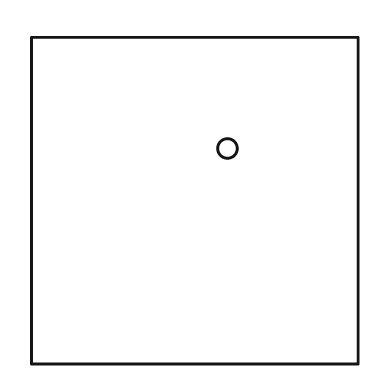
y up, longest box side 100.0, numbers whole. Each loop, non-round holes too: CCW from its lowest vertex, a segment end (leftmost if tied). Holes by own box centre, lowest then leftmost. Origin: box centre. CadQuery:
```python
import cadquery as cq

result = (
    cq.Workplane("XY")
    .moveTo(-50.0, -50.0)
    .lineTo(50.0, -50.0)
    .lineTo(50.0, 50.0)
    .lineTo(-50.0, 50.0)
    .close()
    .moveTo(10.0, 16.0)
    .circle(3.0)
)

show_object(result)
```